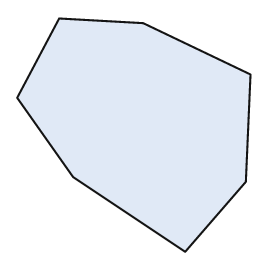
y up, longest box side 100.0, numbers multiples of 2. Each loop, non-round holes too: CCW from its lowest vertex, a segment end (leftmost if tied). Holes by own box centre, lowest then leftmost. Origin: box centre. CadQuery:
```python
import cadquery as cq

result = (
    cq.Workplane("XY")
    .moveTo(22.0, -50.0)
    .lineTo(48.0, -20.0)
    .lineTo(50.0, 26.0)
    .lineTo(4.0, 48.0)
    .lineTo(-32.0, 50.0)
    .lineTo(-50.0, 16.0)
    .lineTo(-26.0, -18.0)
    .close()
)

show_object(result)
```